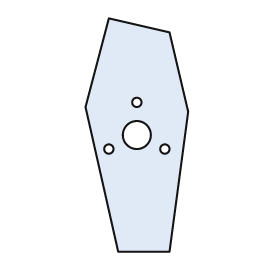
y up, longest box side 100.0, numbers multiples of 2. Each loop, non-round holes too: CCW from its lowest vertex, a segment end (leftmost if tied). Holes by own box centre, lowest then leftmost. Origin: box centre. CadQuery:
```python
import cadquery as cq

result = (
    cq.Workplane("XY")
    .moveTo(-8.0, -50.0)
    .lineTo(14.0, -50.0)
    .lineTo(22.0, 10.0)
    .lineTo(14.0, 44.0)
    .lineTo(-12.0, 50.0)
    .lineTo(-22.0, 12.0)
    .close()
    .moveTo(-12.0, -6.0)
    .circle(2.0)
    .moveTo(12.0, -6.0)
    .circle(2.0)
    .moveTo(0.0, 0.0)
    .circle(6.0)
    .moveTo(0.0, 14.0)
    .circle(2.0)
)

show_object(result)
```